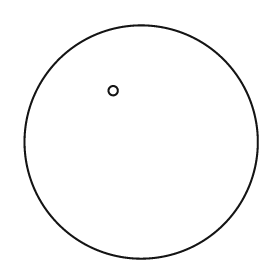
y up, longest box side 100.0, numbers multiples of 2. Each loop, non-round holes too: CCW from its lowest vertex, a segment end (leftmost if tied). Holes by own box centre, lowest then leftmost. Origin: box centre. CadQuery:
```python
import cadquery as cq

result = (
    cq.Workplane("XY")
    .moveTo(0.0, 0.0)
    .circle(50.0)
    .moveTo(-12.0, 22.0)
    .circle(2.0)
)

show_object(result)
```